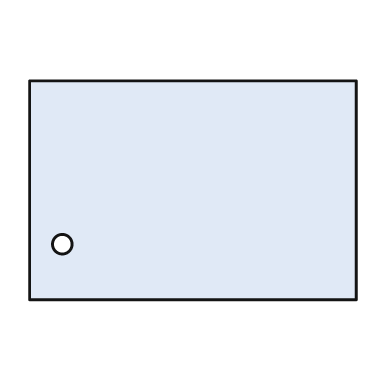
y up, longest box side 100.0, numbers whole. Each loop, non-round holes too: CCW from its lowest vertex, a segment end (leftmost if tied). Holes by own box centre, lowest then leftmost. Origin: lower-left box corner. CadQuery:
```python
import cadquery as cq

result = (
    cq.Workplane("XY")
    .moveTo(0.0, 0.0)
    .lineTo(100.0, 0.0)
    .lineTo(100.0, 67.0)
    .lineTo(0.0, 67.0)
    .close()
    .moveTo(10.0, 17.0)
    .circle(3.0)
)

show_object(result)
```